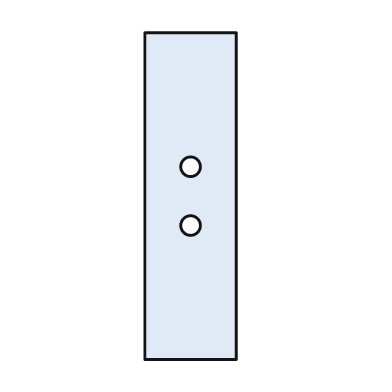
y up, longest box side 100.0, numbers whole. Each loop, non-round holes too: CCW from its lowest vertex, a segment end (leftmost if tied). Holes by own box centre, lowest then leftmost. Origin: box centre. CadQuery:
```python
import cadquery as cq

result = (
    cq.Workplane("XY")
    .moveTo(-14.0, -50.0)
    .lineTo(14.0, -50.0)
    .lineTo(14.0, 50.0)
    .lineTo(-14.0, 50.0)
    .close()
    .moveTo(0.0, -9.0)
    .circle(3.0)
    .moveTo(0.0, 9.0)
    .circle(3.0)
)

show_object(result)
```